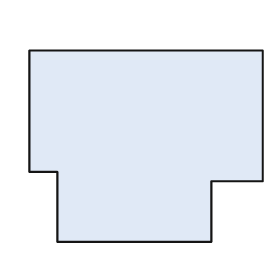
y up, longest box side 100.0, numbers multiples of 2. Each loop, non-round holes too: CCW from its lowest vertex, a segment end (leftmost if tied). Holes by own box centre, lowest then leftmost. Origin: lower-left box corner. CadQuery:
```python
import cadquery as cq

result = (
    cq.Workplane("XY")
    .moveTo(12.0, 0.0)
    .lineTo(78.0, 0.0)
    .lineTo(78.0, 26.0)
    .lineTo(100.0, 26.0)
    .lineTo(100.0, 82.0)
    .lineTo(0.0, 82.0)
    .lineTo(0.0, 30.0)
    .lineTo(12.0, 30.0)
    .close()
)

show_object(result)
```